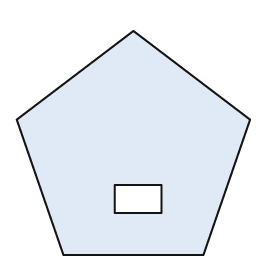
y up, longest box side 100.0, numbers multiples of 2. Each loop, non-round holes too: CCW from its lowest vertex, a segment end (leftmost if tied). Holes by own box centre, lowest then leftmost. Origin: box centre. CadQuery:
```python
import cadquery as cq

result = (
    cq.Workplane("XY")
    .moveTo(-30.0, -48.0)
    .lineTo(30.0, -48.0)
    .lineTo(50.0, 10.0)
    .lineTo(0.0, 48.0)
    .lineTo(-50.0, 10.0)
    .close()
    .moveTo(-8.0, -30.0)
    .lineTo(12.0, -30.0)
    .lineTo(12.0, -18.0)
    .lineTo(-8.0, -18.0)
    .close()
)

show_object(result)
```